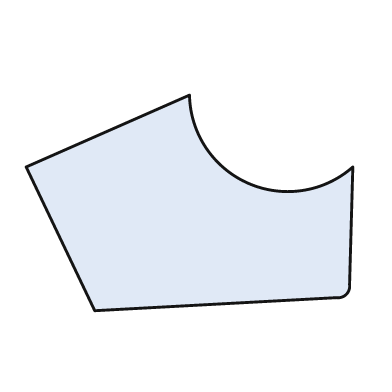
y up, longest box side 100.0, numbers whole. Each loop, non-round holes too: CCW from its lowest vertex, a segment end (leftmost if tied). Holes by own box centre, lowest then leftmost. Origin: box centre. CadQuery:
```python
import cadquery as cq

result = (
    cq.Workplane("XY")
    .moveTo(-29.0, -33.0)
    .lineTo(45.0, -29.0)
    .threePointArc((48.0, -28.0), (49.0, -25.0))
    .lineTo(50.0, 11.0)
    .threePointArc((18.0, 6.0), (0.0, 33.0))
    .lineTo(-50.0, 11.0)
    .close()
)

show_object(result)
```